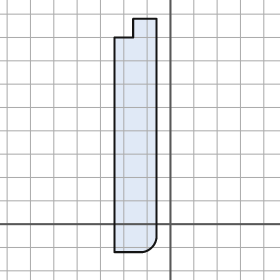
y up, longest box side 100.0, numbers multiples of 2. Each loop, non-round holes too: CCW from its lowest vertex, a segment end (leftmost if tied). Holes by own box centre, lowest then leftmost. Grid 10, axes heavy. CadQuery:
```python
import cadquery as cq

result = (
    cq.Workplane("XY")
    .moveTo(-24.0, -12.0)
    .lineTo(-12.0, -12.0)
    .threePointArc((-8.0, -10.0), (-6.0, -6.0))
    .lineTo(-6.0, 88.0)
    .lineTo(-16.0, 88.0)
    .lineTo(-16.0, 80.0)
    .lineTo(-24.0, 80.0)
    .close()
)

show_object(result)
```